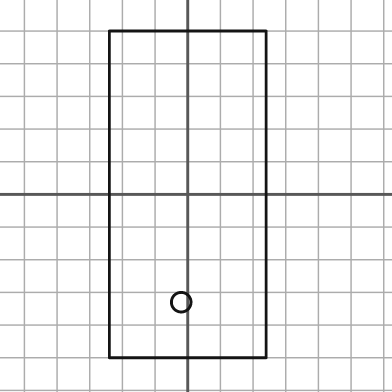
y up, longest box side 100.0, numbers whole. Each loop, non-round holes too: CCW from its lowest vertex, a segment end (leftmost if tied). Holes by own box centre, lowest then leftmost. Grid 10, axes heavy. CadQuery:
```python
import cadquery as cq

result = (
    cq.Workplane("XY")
    .moveTo(-24.0, -50.0)
    .lineTo(24.0, -50.0)
    .lineTo(24.0, 50.0)
    .lineTo(-24.0, 50.0)
    .close()
    .moveTo(-2.0, -33.0)
    .circle(3.0)
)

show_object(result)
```